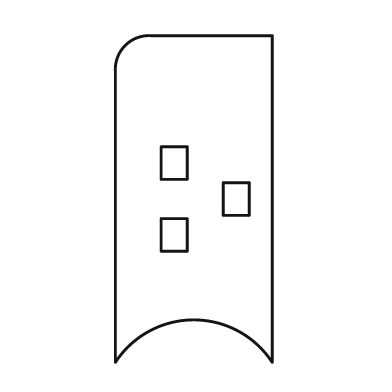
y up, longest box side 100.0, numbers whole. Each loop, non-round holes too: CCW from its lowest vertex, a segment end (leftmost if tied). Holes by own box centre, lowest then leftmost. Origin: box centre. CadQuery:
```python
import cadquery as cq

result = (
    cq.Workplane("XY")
    .moveTo(-24.0, -50.0)
    .threePointArc((0.0, -37.0), (24.0, -50.0))
    .lineTo(24.0, 50.0)
    .lineTo(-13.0, 50.0)
    .threePointArc((-21.0, 47.0), (-24.0, 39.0))
    .close()
    .moveTo(-10.0, -16.0)
    .lineTo(-2.0, -16.0)
    .lineTo(-2.0, -6.0)
    .lineTo(-10.0, -6.0)
    .close()
    .moveTo(9.0, -5.0)
    .lineTo(17.0, -5.0)
    .lineTo(17.0, 5.0)
    .lineTo(9.0, 5.0)
    .close()
    .moveTo(-10.0, 6.0)
    .lineTo(-2.0, 6.0)
    .lineTo(-2.0, 16.0)
    .lineTo(-10.0, 16.0)
    .close()
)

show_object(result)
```